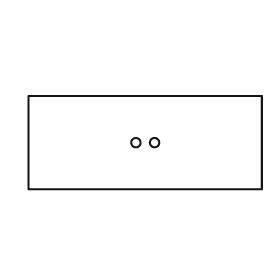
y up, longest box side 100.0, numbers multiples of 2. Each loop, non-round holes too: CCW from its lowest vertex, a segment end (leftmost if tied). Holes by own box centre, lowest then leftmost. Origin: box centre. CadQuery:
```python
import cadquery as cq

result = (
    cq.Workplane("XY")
    .moveTo(-50.0, -20.0)
    .lineTo(50.0, -20.0)
    .lineTo(50.0, 20.0)
    .lineTo(-50.0, 20.0)
    .close()
    .moveTo(-4.0, 0.0)
    .circle(2.0)
    .moveTo(4.0, 0.0)
    .circle(2.0)
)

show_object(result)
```